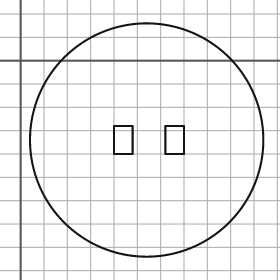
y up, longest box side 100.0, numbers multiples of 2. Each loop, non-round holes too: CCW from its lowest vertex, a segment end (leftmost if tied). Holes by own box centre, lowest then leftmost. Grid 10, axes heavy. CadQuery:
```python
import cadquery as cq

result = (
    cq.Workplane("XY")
    .moveTo(54.0, -34.0)
    .circle(50.0)
    .moveTo(40.0, -40.0)
    .lineTo(48.0, -40.0)
    .lineTo(48.0, -28.0)
    .lineTo(40.0, -28.0)
    .close()
    .moveTo(62.0, -40.0)
    .lineTo(70.0, -40.0)
    .lineTo(70.0, -28.0)
    .lineTo(62.0, -28.0)
    .close()
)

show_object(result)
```